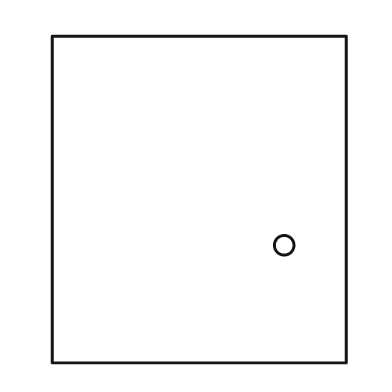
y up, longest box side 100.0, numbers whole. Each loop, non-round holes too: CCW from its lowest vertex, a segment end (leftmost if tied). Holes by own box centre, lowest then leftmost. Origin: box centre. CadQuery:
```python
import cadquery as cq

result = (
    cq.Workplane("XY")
    .moveTo(-45.0, -50.0)
    .lineTo(45.0, -50.0)
    .lineTo(45.0, 50.0)
    .lineTo(-45.0, 50.0)
    .close()
    .moveTo(26.0, -14.0)
    .circle(3.0)
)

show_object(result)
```